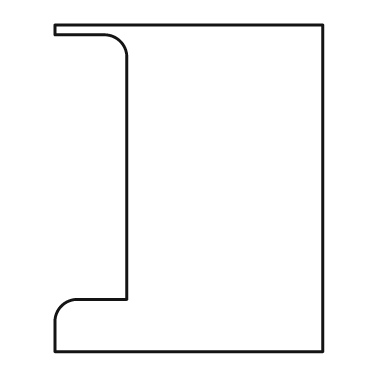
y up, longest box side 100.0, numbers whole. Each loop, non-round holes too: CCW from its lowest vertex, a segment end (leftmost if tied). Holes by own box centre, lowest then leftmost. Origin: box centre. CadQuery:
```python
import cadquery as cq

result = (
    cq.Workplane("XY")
    .moveTo(-41.0, -50.0)
    .lineTo(41.0, -50.0)
    .lineTo(41.0, 50.0)
    .lineTo(-41.0, 50.0)
    .lineTo(-41.0, 47.0)
    .lineTo(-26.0, 47.0)
    .threePointArc((-21.0, 45.0), (-19.0, 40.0))
    .lineTo(-19.0, -34.0)
    .lineTo(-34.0, -34.0)
    .threePointArc((-39.0, -36.0), (-41.0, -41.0))
    .close()
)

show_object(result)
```